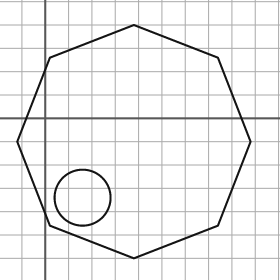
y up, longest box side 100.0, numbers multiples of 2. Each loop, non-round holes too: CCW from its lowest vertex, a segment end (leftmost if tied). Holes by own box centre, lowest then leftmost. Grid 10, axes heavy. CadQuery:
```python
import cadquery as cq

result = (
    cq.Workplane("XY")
    .moveTo(38.0, -60.0)
    .lineTo(74.0, -46.0)
    .lineTo(88.0, -10.0)
    .lineTo(74.0, 26.0)
    .lineTo(38.0, 40.0)
    .lineTo(2.0, 26.0)
    .lineTo(-12.0, -10.0)
    .lineTo(2.0, -46.0)
    .close()
    .moveTo(16.0, -34.0)
    .circle(12.0)
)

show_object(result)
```